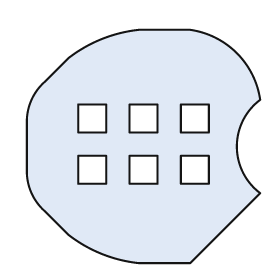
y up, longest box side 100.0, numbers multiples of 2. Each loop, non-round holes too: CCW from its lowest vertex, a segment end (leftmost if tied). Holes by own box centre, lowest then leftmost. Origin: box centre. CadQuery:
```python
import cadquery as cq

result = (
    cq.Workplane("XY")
    .moveTo(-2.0, -50.0)
    .lineTo(20.0, -50.0)
    .lineTo(50.0, -20.0)
    .threePointArc((40.0, 0.0), (50.0, 20.0))
    .threePointArc((40.0, 40.0), (20.0, 50.0))
    .lineTo(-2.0, 50.0)
    .threePointArc((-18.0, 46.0), (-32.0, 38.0))
    .lineTo(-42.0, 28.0)
    .threePointArc((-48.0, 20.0), (-50.0, 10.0))
    .lineTo(-50.0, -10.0)
    .threePointArc((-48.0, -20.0), (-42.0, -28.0))
    .lineTo(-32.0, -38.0)
    .threePointArc((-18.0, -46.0), (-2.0, -50.0))
    .close()
    .moveTo(-28.0, -16.0)
    .lineTo(-16.0, -16.0)
    .lineTo(-16.0, -4.0)
    .lineTo(-28.0, -4.0)
    .close()
    .moveTo(-6.0, -16.0)
    .lineTo(6.0, -16.0)
    .lineTo(6.0, -4.0)
    .lineTo(-6.0, -4.0)
    .close()
    .moveTo(16.0, -16.0)
    .lineTo(28.0, -16.0)
    .lineTo(28.0, -4.0)
    .lineTo(16.0, -4.0)
    .close()
    .moveTo(-28.0, 6.0)
    .lineTo(-16.0, 6.0)
    .lineTo(-16.0, 18.0)
    .lineTo(-28.0, 18.0)
    .close()
    .moveTo(-6.0, 6.0)
    .lineTo(6.0, 6.0)
    .lineTo(6.0, 18.0)
    .lineTo(-6.0, 18.0)
    .close()
    .moveTo(16.0, 6.0)
    .lineTo(28.0, 6.0)
    .lineTo(28.0, 18.0)
    .lineTo(16.0, 18.0)
    .close()
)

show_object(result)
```